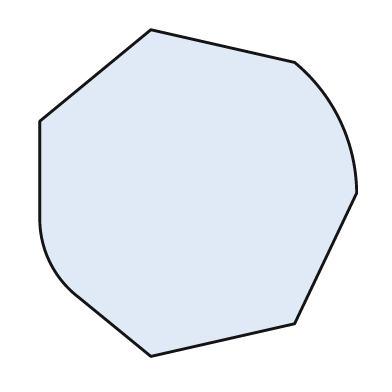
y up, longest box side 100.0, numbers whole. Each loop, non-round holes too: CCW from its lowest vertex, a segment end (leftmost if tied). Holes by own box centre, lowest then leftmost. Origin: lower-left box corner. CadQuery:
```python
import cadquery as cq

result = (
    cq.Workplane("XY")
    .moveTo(34.0, 0.0)
    .lineTo(78.0, 10.0)
    .lineTo(97.0, 50.0)
    .threePointArc((92.0, 72.0), (78.0, 90.0))
    .lineTo(34.0, 100.0)
    .lineTo(0.0, 72.0)
    .lineTo(0.0, 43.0)
    .threePointArc((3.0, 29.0), (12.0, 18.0))
    .close()
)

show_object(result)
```